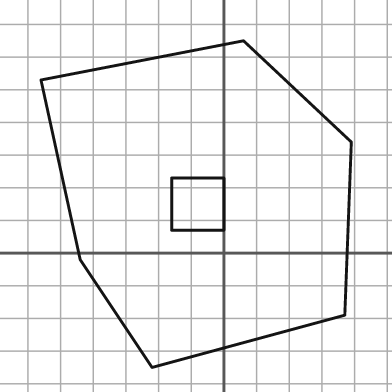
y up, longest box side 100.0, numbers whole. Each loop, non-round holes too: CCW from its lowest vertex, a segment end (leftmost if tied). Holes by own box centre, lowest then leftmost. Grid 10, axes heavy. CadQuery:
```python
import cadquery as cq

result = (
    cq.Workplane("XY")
    .moveTo(-22.0, -35.0)
    .lineTo(37.0, -19.0)
    .lineTo(39.0, 34.0)
    .lineTo(6.0, 65.0)
    .lineTo(-56.0, 53.0)
    .lineTo(-44.0, -2.0)
    .close()
    .moveTo(-16.0, 7.0)
    .lineTo(0.0, 7.0)
    .lineTo(0.0, 23.0)
    .lineTo(-16.0, 23.0)
    .close()
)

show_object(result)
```